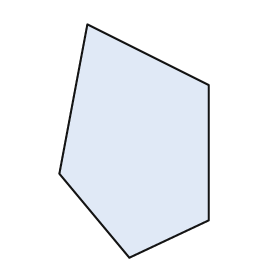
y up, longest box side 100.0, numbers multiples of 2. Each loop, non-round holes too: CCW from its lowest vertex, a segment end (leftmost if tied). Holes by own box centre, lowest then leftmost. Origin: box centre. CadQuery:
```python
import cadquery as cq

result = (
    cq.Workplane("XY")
    .moveTo(-2.0, -50.0)
    .lineTo(32.0, -34.0)
    .lineTo(32.0, 24.0)
    .lineTo(-20.0, 50.0)
    .lineTo(-32.0, -14.0)
    .close()
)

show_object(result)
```